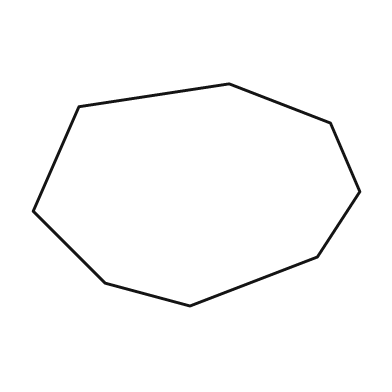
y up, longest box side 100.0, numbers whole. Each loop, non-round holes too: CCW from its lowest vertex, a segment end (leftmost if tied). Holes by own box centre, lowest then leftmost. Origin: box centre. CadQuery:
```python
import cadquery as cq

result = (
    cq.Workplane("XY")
    .moveTo(-2.0, -34.0)
    .lineTo(37.0, -19.0)
    .lineTo(50.0, 1.0)
    .lineTo(41.0, 22.0)
    .lineTo(10.0, 34.0)
    .lineTo(-36.0, 27.0)
    .lineTo(-50.0, -5.0)
    .lineTo(-28.0, -27.0)
    .close()
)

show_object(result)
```